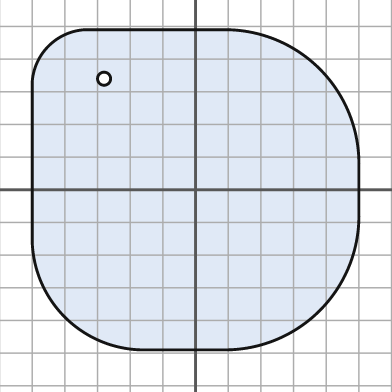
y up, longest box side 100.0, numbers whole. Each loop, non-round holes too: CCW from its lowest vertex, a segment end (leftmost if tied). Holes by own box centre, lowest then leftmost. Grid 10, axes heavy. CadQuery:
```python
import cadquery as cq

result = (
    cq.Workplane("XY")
    .moveTo(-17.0, -49.0)
    .lineTo(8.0, -49.0)
    .threePointArc((38.0, -37.0), (50.0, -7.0))
    .lineTo(50.0, 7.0)
    .threePointArc((38.0, 37.0), (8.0, 49.0))
    .lineTo(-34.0, 49.0)
    .threePointArc((-45.0, 44.0), (-50.0, 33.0))
    .lineTo(-50.0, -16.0)
    .threePointArc((-40.0, -39.0), (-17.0, -49.0))
    .close()
    .moveTo(-28.0, 34.0)
    .circle(2.0)
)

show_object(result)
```